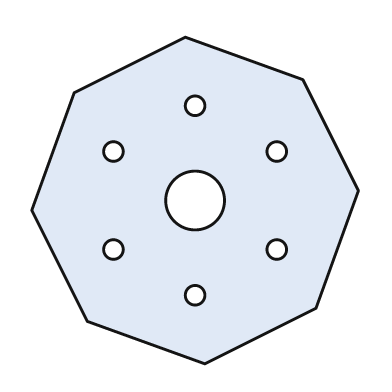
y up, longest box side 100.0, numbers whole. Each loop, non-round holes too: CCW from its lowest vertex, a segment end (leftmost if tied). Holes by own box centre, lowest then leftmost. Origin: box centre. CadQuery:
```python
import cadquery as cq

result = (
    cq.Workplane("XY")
    .moveTo(3.0, -50.0)
    .lineTo(37.0, -33.0)
    .lineTo(50.0, 3.0)
    .lineTo(33.0, 37.0)
    .lineTo(-3.0, 50.0)
    .lineTo(-37.0, 33.0)
    .lineTo(-50.0, -3.0)
    .lineTo(-33.0, -37.0)
    .close()
    .moveTo(0.0, -29.0)
    .circle(3.0)
    .moveTo(-25.0, -15.0)
    .circle(3.0)
    .moveTo(25.0, -15.0)
    .circle(3.0)
    .moveTo(0.0, 0.0)
    .circle(9.0)
    .moveTo(-25.0, 15.0)
    .circle(3.0)
    .moveTo(25.0, 15.0)
    .circle(3.0)
    .moveTo(0.0, 29.0)
    .circle(3.0)
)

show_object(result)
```